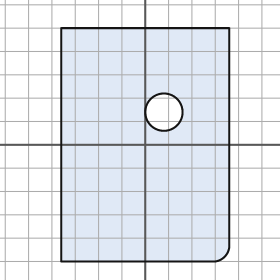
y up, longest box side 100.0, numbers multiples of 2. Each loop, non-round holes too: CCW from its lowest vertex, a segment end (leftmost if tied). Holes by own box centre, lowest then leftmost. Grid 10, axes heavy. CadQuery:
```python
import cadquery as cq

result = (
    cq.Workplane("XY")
    .moveTo(-36.0, -50.0)
    .lineTo(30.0, -50.0)
    .threePointArc((34.0, -48.0), (36.0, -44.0))
    .lineTo(36.0, 50.0)
    .lineTo(-36.0, 50.0)
    .close()
    .moveTo(8.0, 14.0)
    .circle(8.0)
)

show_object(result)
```